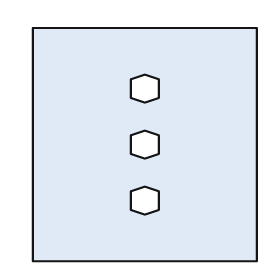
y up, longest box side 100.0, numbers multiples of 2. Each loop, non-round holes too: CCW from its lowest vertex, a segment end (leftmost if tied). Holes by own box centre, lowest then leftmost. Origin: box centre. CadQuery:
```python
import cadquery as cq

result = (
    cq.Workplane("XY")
    .moveTo(-48.0, -50.0)
    .lineTo(48.0, -50.0)
    .lineTo(48.0, 50.0)
    .lineTo(-48.0, 50.0)
    .close()
    .moveTo(0.0, -30.0)
    .lineTo(6.0, -28.0)
    .lineTo(6.0, -20.0)
    .lineTo(0.0, -18.0)
    .lineTo(-6.0, -20.0)
    .lineTo(-6.0, -28.0)
    .close()
    .moveTo(0.0, -6.0)
    .lineTo(6.0, -4.0)
    .lineTo(6.0, 4.0)
    .lineTo(0.0, 6.0)
    .lineTo(-6.0, 4.0)
    .lineTo(-6.0, -4.0)
    .close()
    .moveTo(0.0, 18.0)
    .lineTo(6.0, 20.0)
    .lineTo(6.0, 28.0)
    .lineTo(0.0, 30.0)
    .lineTo(-6.0, 28.0)
    .lineTo(-6.0, 20.0)
    .close()
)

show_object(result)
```